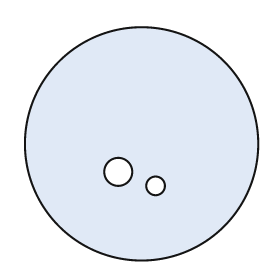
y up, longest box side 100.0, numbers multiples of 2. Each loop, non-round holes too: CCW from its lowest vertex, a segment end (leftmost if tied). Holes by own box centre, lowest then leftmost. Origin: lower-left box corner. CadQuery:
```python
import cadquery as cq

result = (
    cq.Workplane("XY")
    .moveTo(50.0, 50.0)
    .circle(50.0)
    .moveTo(56.0, 32.0)
    .circle(4.0)
    .moveTo(40.0, 38.0)
    .circle(6.0)
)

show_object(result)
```